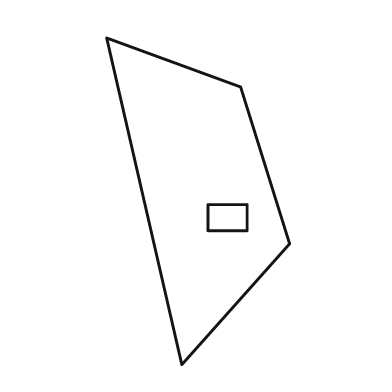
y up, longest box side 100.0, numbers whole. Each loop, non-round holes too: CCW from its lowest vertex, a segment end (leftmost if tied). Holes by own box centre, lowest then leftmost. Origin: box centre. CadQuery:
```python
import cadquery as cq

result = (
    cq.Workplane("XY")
    .moveTo(-5.0, -50.0)
    .lineTo(28.0, -13.0)
    .lineTo(13.0, 35.0)
    .lineTo(-28.0, 50.0)
    .close()
    .moveTo(3.0, -9.0)
    .lineTo(15.0, -9.0)
    .lineTo(15.0, -1.0)
    .lineTo(3.0, -1.0)
    .close()
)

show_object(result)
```